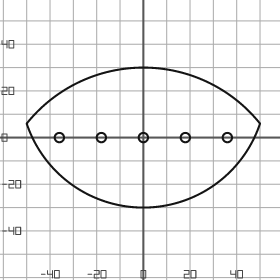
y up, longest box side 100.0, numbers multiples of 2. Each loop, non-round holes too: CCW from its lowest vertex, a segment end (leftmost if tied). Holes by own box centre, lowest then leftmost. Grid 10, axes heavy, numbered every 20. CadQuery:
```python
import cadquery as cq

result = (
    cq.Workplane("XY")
    .moveTo(-50.0, 6.0)
    .threePointArc((0.0, -30.0), (50.0, 6.0))
    .threePointArc((0.0, 30.0), (-50.0, 6.0))
    .close()
    .moveTo(-36.0, 0.0)
    .circle(2.0)
    .moveTo(-18.0, 0.0)
    .circle(2.0)
    .moveTo(0.0, 0.0)
    .circle(2.0)
    .moveTo(18.0, 0.0)
    .circle(2.0)
    .moveTo(36.0, 0.0)
    .circle(2.0)
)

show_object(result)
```